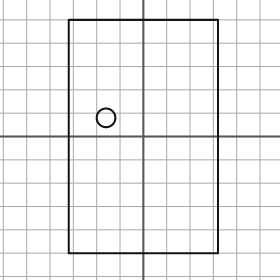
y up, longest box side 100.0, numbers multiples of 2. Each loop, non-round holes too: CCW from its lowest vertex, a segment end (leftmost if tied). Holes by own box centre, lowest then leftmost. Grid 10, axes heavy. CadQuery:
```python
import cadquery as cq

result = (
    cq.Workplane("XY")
    .moveTo(-32.0, -50.0)
    .lineTo(32.0, -50.0)
    .lineTo(32.0, 50.0)
    .lineTo(-32.0, 50.0)
    .close()
    .moveTo(-16.0, 8.0)
    .circle(4.0)
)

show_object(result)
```